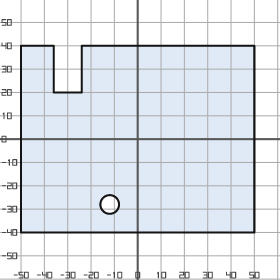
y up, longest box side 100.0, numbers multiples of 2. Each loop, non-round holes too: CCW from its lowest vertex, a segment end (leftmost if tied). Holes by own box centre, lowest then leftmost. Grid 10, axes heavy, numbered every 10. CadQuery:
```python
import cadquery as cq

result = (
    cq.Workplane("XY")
    .moveTo(-50.0, -40.0)
    .lineTo(50.0, -40.0)
    .lineTo(50.0, 40.0)
    .lineTo(-24.0, 40.0)
    .lineTo(-24.0, 20.0)
    .lineTo(-36.0, 20.0)
    .lineTo(-36.0, 40.0)
    .lineTo(-50.0, 40.0)
    .close()
    .moveTo(-12.0, -28.0)
    .circle(4.0)
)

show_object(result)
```